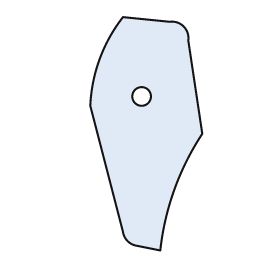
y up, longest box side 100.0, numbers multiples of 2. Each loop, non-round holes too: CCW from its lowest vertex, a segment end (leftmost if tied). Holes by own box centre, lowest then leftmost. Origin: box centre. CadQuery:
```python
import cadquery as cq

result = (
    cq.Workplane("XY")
    .moveTo(6.0, -50.0)
    .threePointArc((12.0, -24.0), (24.0, 0.0))
    .lineTo(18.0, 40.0)
    .threePointArc((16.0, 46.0), (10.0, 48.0))
    .lineTo(-10.0, 50.0)
    .threePointArc((-20.0, 32.0), (-24.0, 12.0))
    .lineTo(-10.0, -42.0)
    .threePointArc((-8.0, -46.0), (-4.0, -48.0))
    .close()
    .moveTo(-2.0, 16.0)
    .circle(4.0)
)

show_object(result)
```